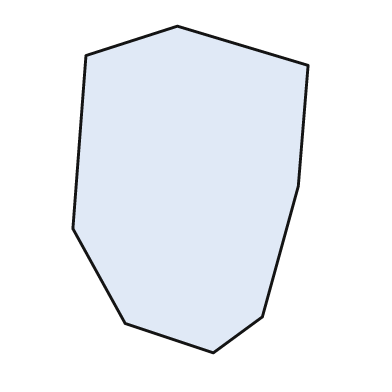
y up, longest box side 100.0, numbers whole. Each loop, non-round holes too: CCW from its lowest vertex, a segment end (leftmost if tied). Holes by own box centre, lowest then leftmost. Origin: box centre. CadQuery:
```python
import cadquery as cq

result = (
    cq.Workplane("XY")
    .moveTo(7.0, -50.0)
    .lineTo(22.0, -39.0)
    .lineTo(33.0, 1.0)
    .lineTo(36.0, 38.0)
    .lineTo(-4.0, 50.0)
    .lineTo(-32.0, 41.0)
    .lineTo(-36.0, -12.0)
    .lineTo(-20.0, -41.0)
    .close()
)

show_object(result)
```